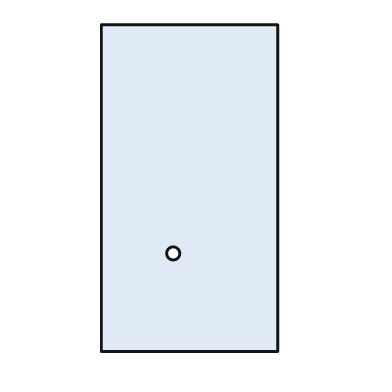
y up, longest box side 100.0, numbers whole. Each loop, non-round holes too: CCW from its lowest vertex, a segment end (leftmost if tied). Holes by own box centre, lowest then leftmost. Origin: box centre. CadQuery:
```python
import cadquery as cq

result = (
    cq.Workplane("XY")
    .moveTo(-27.0, -50.0)
    .lineTo(27.0, -50.0)
    .lineTo(27.0, 50.0)
    .lineTo(-27.0, 50.0)
    .close()
    .moveTo(-5.0, -20.0)
    .circle(2.0)
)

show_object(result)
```